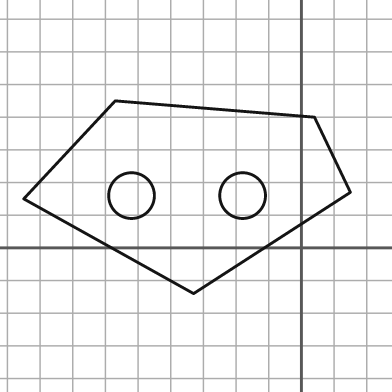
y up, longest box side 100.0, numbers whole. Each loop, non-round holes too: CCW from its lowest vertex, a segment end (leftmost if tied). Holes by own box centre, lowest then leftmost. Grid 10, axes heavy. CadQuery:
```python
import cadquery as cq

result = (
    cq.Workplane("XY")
    .moveTo(-33.0, -14.0)
    .lineTo(15.0, 17.0)
    .lineTo(4.0, 40.0)
    .lineTo(-57.0, 45.0)
    .lineTo(-85.0, 15.0)
    .close()
    .moveTo(-52.0, 16.0)
    .circle(7.0)
    .moveTo(-18.0, 16.0)
    .circle(7.0)
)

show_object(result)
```